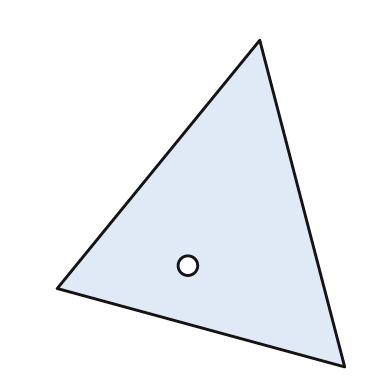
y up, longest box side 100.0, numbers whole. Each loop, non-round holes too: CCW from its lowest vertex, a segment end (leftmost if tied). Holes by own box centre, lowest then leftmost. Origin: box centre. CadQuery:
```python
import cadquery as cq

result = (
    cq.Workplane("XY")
    .moveTo(44.0, -50.0)
    .lineTo(18.0, 50.0)
    .lineTo(-44.0, -26.0)
    .close()
    .moveTo(-4.0, -19.0)
    .circle(3.0)
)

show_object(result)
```